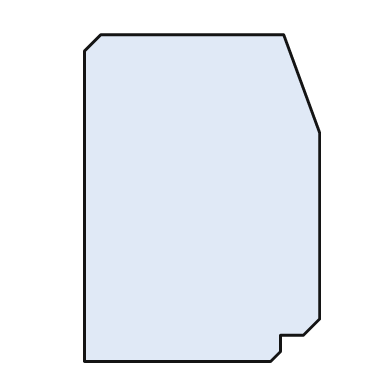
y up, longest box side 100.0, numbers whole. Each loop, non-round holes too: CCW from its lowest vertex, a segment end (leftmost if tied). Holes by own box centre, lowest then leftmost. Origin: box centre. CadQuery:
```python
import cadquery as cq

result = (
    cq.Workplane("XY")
    .moveTo(-36.0, -50.0)
    .lineTo(21.0, -50.0)
    .lineTo(24.0, -47.0)
    .lineTo(24.0, -42.0)
    .lineTo(31.0, -42.0)
    .lineTo(36.0, -37.0)
    .lineTo(36.0, 20.0)
    .lineTo(25.0, 50.0)
    .lineTo(-31.0, 50.0)
    .lineTo(-36.0, 45.0)
    .close()
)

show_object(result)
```